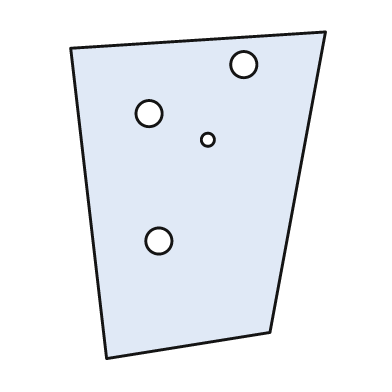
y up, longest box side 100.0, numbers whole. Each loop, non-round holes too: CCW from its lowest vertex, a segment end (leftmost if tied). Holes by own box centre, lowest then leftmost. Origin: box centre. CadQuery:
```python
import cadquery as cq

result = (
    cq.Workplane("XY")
    .moveTo(-28.0, -50.0)
    .lineTo(22.0, -42.0)
    .lineTo(39.0, 50.0)
    .lineTo(-39.0, 45.0)
    .close()
    .moveTo(-12.0, -14.0)
    .circle(4.0)
    .moveTo(3.0, 17.0)
    .circle(2.0)
    .moveTo(-15.0, 25.0)
    .circle(4.0)
    .moveTo(14.0, 40.0)
    .circle(4.0)
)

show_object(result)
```